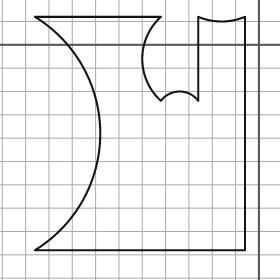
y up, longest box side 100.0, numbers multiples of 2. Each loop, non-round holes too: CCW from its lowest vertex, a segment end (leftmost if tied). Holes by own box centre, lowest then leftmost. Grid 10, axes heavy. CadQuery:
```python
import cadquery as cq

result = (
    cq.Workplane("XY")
    .moveTo(-96.0, -88.0)
    .lineTo(-6.0, -88.0)
    .lineTo(-6.0, 12.0)
    .threePointArc((-16.0, 10.0), (-26.0, 12.0))
    .lineTo(-26.0, -24.0)
    .threePointArc((-34.0, -20.0), (-42.0, -24.0))
    .threePointArc((-50.0, -6.0), (-42.0, 12.0))
    .lineTo(-96.0, 12.0)
    .threePointArc((-68.0, -38.0), (-96.0, -88.0))
    .close()
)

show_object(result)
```